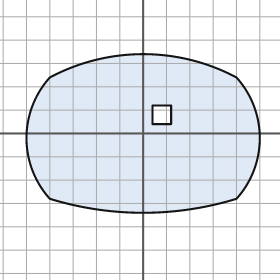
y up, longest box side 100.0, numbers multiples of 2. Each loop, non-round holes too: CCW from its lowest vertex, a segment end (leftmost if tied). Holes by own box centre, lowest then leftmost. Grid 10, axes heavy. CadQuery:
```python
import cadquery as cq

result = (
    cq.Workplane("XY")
    .moveTo(-40.0, -28.0)
    .threePointArc((0.0, -34.0), (40.0, -28.0))
    .threePointArc((50.0, -2.0), (40.0, 24.0))
    .threePointArc((0.0, 34.0), (-40.0, 24.0))
    .threePointArc((-50.0, -2.0), (-40.0, -28.0))
    .close()
    .moveTo(4.0, 4.0)
    .lineTo(12.0, 4.0)
    .lineTo(12.0, 12.0)
    .lineTo(4.0, 12.0)
    .close()
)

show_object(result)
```